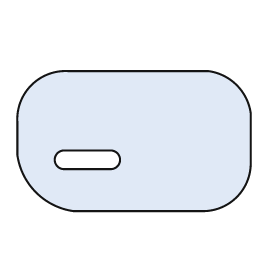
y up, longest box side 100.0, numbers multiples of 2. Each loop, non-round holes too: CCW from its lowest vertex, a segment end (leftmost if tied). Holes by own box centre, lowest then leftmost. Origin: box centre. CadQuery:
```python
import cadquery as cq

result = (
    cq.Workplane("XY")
    .moveTo(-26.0, -30.0)
    .lineTo(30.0, -30.0)
    .threePointArc((44.0, -24.0), (50.0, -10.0))
    .lineTo(50.0, 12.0)
    .threePointArc((44.0, 24.0), (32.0, 30.0))
    .lineTo(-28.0, 30.0)
    .threePointArc((-44.0, 24.0), (-50.0, 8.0))
    .lineTo(-50.0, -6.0)
    .threePointArc((-42.0, -22.0), (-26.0, -30.0))
    .close()
    .moveTo(-30.0, -12.0)
    .lineTo(-10.0, -12.0)
    .threePointArc((-6.0, -8.0), (-10.0, -4.0))
    .lineTo(-30.0, -4.0)
    .threePointArc((-34.0, -8.0), (-30.0, -12.0))
    .close()
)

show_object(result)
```